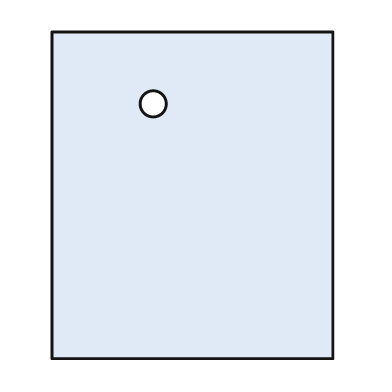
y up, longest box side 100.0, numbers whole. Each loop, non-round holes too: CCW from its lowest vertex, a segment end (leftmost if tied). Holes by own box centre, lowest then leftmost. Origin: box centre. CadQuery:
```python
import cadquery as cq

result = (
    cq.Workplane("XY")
    .moveTo(-43.0, -50.0)
    .lineTo(43.0, -50.0)
    .lineTo(43.0, 50.0)
    .lineTo(-43.0, 50.0)
    .close()
    .moveTo(-12.0, 28.0)
    .circle(4.0)
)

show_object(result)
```